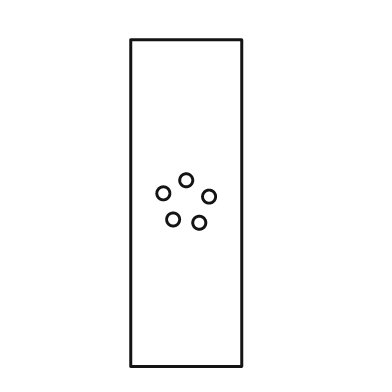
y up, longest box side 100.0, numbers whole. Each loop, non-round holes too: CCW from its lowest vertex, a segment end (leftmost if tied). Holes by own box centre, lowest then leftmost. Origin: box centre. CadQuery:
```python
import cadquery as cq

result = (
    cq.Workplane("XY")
    .moveTo(-17.0, -50.0)
    .lineTo(17.0, -50.0)
    .lineTo(17.0, 50.0)
    .lineTo(-17.0, 50.0)
    .close()
    .moveTo(4.0, -6.0)
    .circle(2.0)
    .moveTo(-4.0, -5.0)
    .circle(2.0)
    .moveTo(7.0, 2.0)
    .circle(2.0)
    .moveTo(-7.0, 3.0)
    .circle(2.0)
    .moveTo(0.0, 7.0)
    .circle(2.0)
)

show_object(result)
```